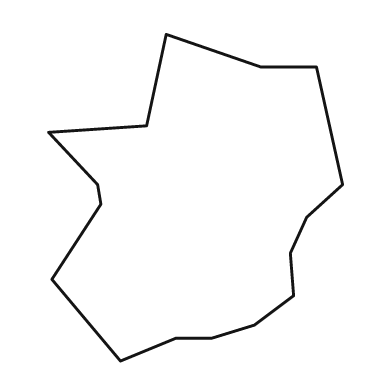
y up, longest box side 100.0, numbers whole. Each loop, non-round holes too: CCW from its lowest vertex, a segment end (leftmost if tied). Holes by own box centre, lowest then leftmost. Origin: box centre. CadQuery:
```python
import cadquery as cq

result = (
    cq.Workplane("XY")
    .moveTo(-23.0, -50.0)
    .lineTo(-6.0, -43.0)
    .lineTo(5.0, -43.0)
    .lineTo(18.0, -39.0)
    .lineTo(30.0, -30.0)
    .lineTo(29.0, -17.0)
    .lineTo(34.0, -6.0)
    .lineTo(45.0, 4.0)
    .lineTo(37.0, 40.0)
    .lineTo(20.0, 40.0)
    .lineTo(-9.0, 50.0)
    .lineTo(-15.0, 22.0)
    .lineTo(-45.0, 20.0)
    .lineTo(-30.0, 4.0)
    .lineTo(-29.0, -2.0)
    .lineTo(-44.0, -25.0)
    .close()
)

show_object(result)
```